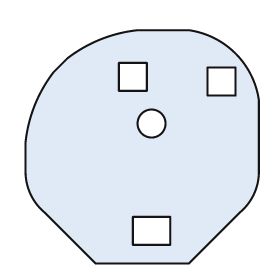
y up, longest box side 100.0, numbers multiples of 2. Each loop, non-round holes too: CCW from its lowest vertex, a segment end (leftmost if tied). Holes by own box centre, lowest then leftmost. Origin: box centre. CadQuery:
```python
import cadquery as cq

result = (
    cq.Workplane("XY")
    .moveTo(-20.0, -50.0)
    .lineTo(20.0, -50.0)
    .lineTo(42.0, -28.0)
    .threePointArc((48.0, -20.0), (50.0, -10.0))
    .lineTo(50.0, 20.0)
    .threePointArc((40.0, 40.0), (20.0, 50.0))
    .lineTo(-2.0, 50.0)
    .threePointArc((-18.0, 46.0), (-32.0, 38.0))
    .lineTo(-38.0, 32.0)
    .threePointArc((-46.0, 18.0), (-50.0, 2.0))
    .lineTo(-50.0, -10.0)
    .threePointArc((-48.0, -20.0), (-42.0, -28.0))
    .close()
    .moveTo(-4.0, -42.0)
    .lineTo(12.0, -42.0)
    .lineTo(12.0, -30.0)
    .lineTo(-4.0, -30.0)
    .close()
    .moveTo(4.0, 10.0)
    .circle(6.0)
    .moveTo(28.0, 22.0)
    .lineTo(40.0, 22.0)
    .lineTo(40.0, 34.0)
    .lineTo(28.0, 34.0)
    .close()
    .moveTo(-10.0, 24.0)
    .lineTo(2.0, 24.0)
    .lineTo(2.0, 36.0)
    .lineTo(-10.0, 36.0)
    .close()
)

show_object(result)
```